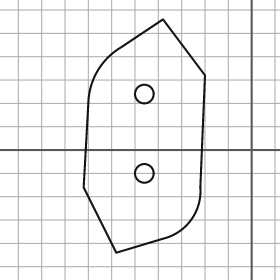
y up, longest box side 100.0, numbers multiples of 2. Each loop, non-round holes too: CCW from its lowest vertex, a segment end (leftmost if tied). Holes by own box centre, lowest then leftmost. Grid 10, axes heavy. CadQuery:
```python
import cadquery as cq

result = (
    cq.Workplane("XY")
    .moveTo(-58.0, -44.0)
    .lineTo(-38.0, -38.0)
    .threePointArc((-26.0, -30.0), (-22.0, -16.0))
    .lineTo(-20.0, 32.0)
    .lineTo(-38.0, 56.0)
    .lineTo(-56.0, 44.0)
    .threePointArc((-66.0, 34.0), (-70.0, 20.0))
    .lineTo(-72.0, -16.0)
    .close()
    .moveTo(-46.0, -10.0)
    .circle(4.0)
    .moveTo(-46.0, 24.0)
    .circle(4.0)
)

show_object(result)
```